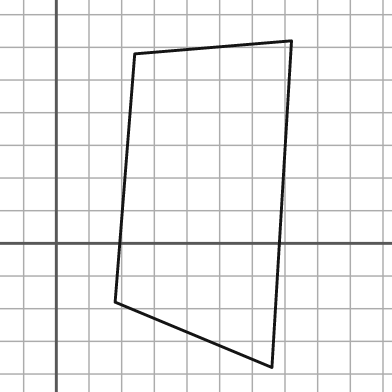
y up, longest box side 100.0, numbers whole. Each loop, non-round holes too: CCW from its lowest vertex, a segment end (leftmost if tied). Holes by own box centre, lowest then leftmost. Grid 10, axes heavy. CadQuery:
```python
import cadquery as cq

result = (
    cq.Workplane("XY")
    .moveTo(66.0, -38.0)
    .lineTo(72.0, 62.0)
    .lineTo(24.0, 58.0)
    .lineTo(18.0, -18.0)
    .close()
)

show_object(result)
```